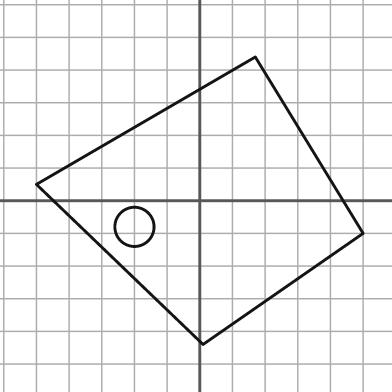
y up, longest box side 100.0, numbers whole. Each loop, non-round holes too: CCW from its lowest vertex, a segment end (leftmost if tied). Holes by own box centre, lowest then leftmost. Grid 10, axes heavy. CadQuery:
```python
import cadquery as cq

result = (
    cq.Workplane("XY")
    .moveTo(1.0, -44.0)
    .lineTo(50.0, -10.0)
    .lineTo(17.0, 44.0)
    .lineTo(-50.0, 5.0)
    .close()
    .moveTo(-20.0, -8.0)
    .circle(6.0)
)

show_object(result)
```